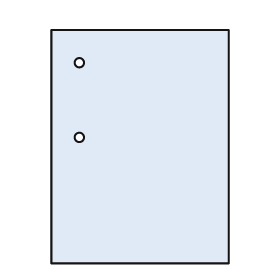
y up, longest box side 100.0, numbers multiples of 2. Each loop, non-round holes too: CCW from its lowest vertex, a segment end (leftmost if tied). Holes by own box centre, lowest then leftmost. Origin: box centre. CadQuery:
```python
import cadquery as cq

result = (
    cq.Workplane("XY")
    .moveTo(-38.0, -50.0)
    .lineTo(38.0, -50.0)
    .lineTo(38.0, 50.0)
    .lineTo(-38.0, 50.0)
    .close()
    .moveTo(-26.0, 4.0)
    .circle(2.0)
    .moveTo(-26.0, 36.0)
    .circle(2.0)
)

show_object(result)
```